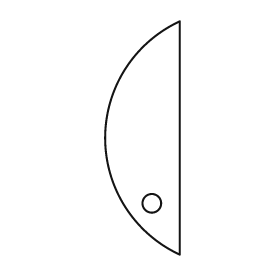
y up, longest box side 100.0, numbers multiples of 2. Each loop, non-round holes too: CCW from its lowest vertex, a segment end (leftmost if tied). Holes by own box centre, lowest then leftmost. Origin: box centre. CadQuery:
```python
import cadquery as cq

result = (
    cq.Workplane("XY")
    .moveTo(16.0, -50.0)
    .lineTo(16.0, 50.0)
    .threePointArc((-16.0, 0.0), (16.0, -50.0))
    .close()
    .moveTo(4.0, -28.0)
    .circle(4.0)
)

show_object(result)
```